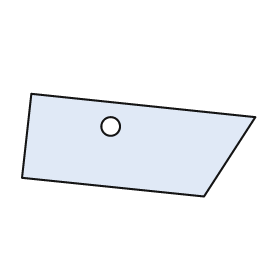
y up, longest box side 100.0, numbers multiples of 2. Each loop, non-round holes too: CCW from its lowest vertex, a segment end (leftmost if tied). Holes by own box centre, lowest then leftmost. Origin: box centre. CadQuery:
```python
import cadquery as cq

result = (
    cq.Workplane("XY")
    .moveTo(28.0, -22.0)
    .lineTo(50.0, 12.0)
    .lineTo(-46.0, 22.0)
    .lineTo(-50.0, -14.0)
    .close()
    .moveTo(-12.0, 8.0)
    .circle(4.0)
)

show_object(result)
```